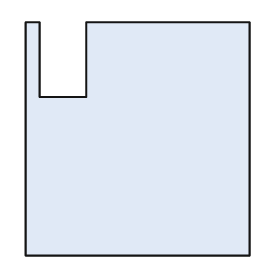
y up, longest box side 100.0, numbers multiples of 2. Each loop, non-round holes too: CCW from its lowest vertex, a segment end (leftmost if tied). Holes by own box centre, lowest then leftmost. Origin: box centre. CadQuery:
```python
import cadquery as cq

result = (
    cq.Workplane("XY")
    .moveTo(-48.0, -50.0)
    .lineTo(48.0, -50.0)
    .lineTo(48.0, 50.0)
    .lineTo(-22.0, 50.0)
    .lineTo(-22.0, 18.0)
    .lineTo(-42.0, 18.0)
    .lineTo(-42.0, 50.0)
    .lineTo(-48.0, 50.0)
    .close()
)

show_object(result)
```